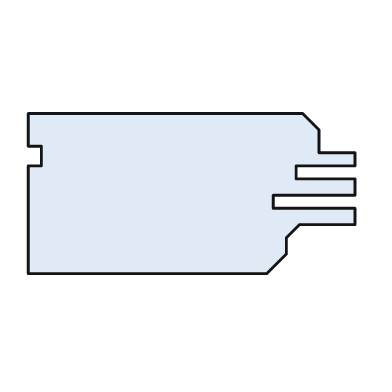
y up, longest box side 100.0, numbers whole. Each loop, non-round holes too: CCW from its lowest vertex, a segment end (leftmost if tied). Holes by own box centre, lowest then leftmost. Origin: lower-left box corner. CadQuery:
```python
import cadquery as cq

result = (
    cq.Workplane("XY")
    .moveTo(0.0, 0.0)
    .lineTo(73.0, 0.0)
    .lineTo(79.0, 6.0)
    .lineTo(79.0, 11.0)
    .lineTo(83.0, 15.0)
    .lineTo(100.0, 15.0)
    .lineTo(100.0, 20.0)
    .lineTo(75.0, 20.0)
    .lineTo(75.0, 24.0)
    .lineTo(100.0, 24.0)
    .lineTo(100.0, 29.0)
    .lineTo(82.0, 29.0)
    .lineTo(82.0, 33.0)
    .lineTo(100.0, 33.0)
    .lineTo(100.0, 37.0)
    .lineTo(89.0, 37.0)
    .lineTo(89.0, 44.0)
    .lineTo(84.0, 49.0)
    .lineTo(0.0, 49.0)
    .lineTo(0.0, 39.0)
    .lineTo(4.0, 39.0)
    .lineTo(4.0, 33.0)
    .lineTo(0.0, 33.0)
    .close()
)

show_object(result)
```